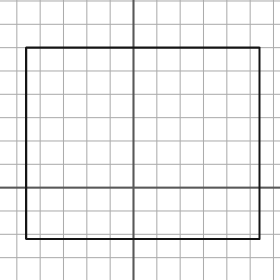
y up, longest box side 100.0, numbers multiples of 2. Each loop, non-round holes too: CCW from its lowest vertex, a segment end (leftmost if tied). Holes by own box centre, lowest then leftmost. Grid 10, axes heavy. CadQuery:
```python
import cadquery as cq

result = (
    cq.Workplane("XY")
    .moveTo(-46.0, -22.0)
    .lineTo(54.0, -22.0)
    .lineTo(54.0, 60.0)
    .lineTo(-46.0, 60.0)
    .close()
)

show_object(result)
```